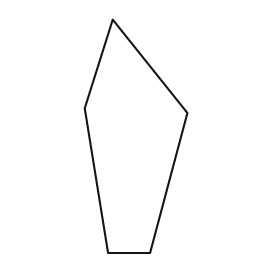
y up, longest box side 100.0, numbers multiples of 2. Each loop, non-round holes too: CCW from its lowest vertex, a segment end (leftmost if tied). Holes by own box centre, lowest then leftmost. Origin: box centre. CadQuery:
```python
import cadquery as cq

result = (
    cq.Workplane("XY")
    .moveTo(-12.0, -50.0)
    .lineTo(6.0, -50.0)
    .lineTo(22.0, 10.0)
    .lineTo(-10.0, 50.0)
    .lineTo(-22.0, 12.0)
    .close()
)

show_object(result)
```